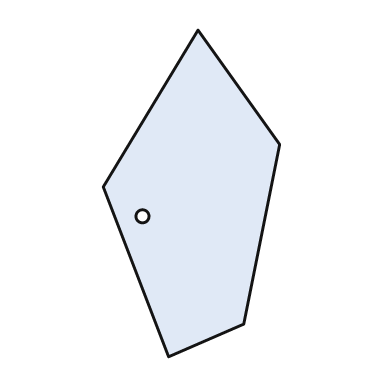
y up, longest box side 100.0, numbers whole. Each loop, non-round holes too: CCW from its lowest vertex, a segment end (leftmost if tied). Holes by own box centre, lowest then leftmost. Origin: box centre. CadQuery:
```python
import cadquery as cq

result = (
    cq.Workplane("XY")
    .moveTo(-7.0, -50.0)
    .lineTo(16.0, -40.0)
    .lineTo(27.0, 15.0)
    .lineTo(2.0, 50.0)
    .lineTo(-27.0, 2.0)
    .close()
    .moveTo(-15.0, -7.0)
    .circle(2.0)
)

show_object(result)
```